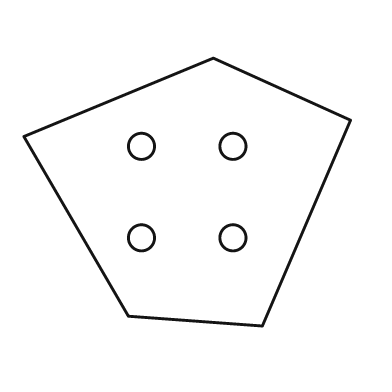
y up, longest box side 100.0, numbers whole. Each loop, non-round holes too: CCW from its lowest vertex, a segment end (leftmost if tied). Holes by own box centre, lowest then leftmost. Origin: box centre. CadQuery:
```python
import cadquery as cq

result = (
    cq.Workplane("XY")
    .moveTo(23.0, -41.0)
    .lineTo(50.0, 22.0)
    .lineTo(8.0, 41.0)
    .lineTo(-50.0, 17.0)
    .lineTo(-18.0, -38.0)
    .close()
    .moveTo(-14.0, -14.0)
    .circle(4.0)
    .moveTo(14.0, -14.0)
    .circle(4.0)
    .moveTo(-14.0, 14.0)
    .circle(4.0)
    .moveTo(14.0, 14.0)
    .circle(4.0)
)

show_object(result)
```